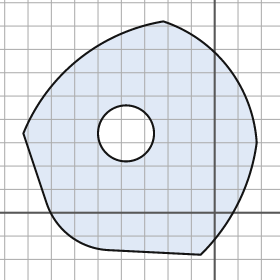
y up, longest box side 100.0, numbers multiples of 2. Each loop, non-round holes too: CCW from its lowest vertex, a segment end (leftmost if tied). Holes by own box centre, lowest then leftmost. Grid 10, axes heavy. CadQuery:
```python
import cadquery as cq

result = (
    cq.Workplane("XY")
    .moveTo(-6.0, -18.0)
    .threePointArc((10.0, 4.0), (18.0, 30.0))
    .threePointArc((6.0, 62.0), (-22.0, 82.0))
    .threePointArc((-58.0, 66.0), (-82.0, 34.0))
    .lineTo(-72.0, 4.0)
    .threePointArc((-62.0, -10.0), (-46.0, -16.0))
    .close()
    .moveTo(-38.0, 34.0)
    .circle(12.0)
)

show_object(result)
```